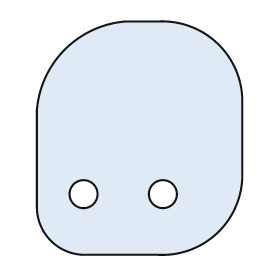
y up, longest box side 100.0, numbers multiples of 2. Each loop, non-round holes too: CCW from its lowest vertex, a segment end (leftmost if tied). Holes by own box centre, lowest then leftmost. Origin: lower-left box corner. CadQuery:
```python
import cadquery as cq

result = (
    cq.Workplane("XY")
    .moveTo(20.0, 0.0)
    .lineTo(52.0, 0.0)
    .threePointArc((78.0, 10.0), (88.0, 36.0))
    .lineTo(88.0, 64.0)
    .threePointArc((78.0, 90.0), (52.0, 100.0))
    .lineTo(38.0, 100.0)
    .threePointArc((12.0, 88.0), (0.0, 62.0))
    .lineTo(0.0, 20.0)
    .threePointArc((6.0, 6.0), (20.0, 0.0))
    .close()
    .moveTo(20.0, 26.0)
    .circle(6.0)
    .moveTo(54.0, 26.0)
    .circle(6.0)
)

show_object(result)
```